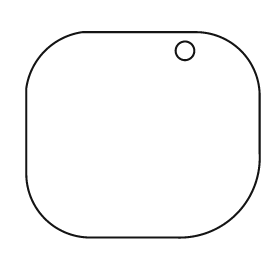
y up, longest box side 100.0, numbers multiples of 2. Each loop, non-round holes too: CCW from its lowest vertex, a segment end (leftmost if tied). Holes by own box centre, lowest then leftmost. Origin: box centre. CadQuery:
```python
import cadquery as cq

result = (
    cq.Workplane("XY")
    .moveTo(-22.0, -44.0)
    .lineTo(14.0, -44.0)
    .threePointArc((40.0, -34.0), (50.0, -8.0))
    .lineTo(50.0, 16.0)
    .threePointArc((42.0, 36.0), (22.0, 44.0))
    .lineTo(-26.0, 44.0)
    .threePointArc((-42.0, 36.0), (-50.0, 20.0))
    .lineTo(-50.0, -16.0)
    .threePointArc((-42.0, -36.0), (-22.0, -44.0))
    .close()
    .moveTo(18.0, 36.0)
    .circle(4.0)
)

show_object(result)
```